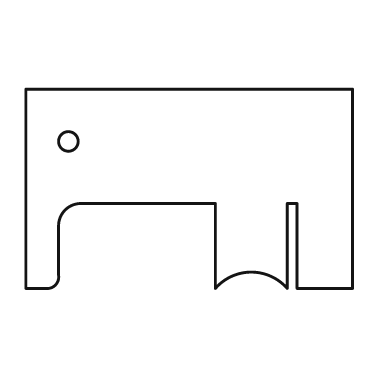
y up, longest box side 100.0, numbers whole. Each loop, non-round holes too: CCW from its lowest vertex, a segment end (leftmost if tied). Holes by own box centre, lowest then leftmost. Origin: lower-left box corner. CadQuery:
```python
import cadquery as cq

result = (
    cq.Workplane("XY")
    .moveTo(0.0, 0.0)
    .lineTo(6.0, 0.0)
    .threePointArc((9.0, 1.0), (10.0, 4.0))
    .lineTo(10.0, 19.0)
    .threePointArc((12.0, 24.0), (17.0, 26.0))
    .lineTo(58.0, 26.0)
    .lineTo(58.0, 0.0)
    .threePointArc((69.0, 5.0), (80.0, 0.0))
    .lineTo(80.0, 26.0)
    .lineTo(83.0, 26.0)
    .lineTo(83.0, 0.0)
    .lineTo(100.0, 0.0)
    .lineTo(100.0, 61.0)
    .lineTo(0.0, 61.0)
    .close()
    .moveTo(13.0, 45.0)
    .circle(3.0)
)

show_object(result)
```